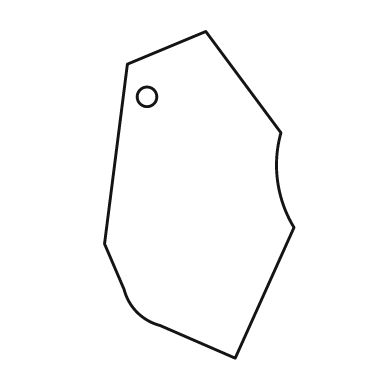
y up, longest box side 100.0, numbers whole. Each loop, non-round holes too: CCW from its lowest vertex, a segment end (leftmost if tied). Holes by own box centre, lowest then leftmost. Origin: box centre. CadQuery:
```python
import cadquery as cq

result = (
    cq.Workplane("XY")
    .moveTo(11.0, -50.0)
    .lineTo(29.0, -10.0)
    .threePointArc((24.0, 4.0), (25.0, 19.0))
    .lineTo(2.0, 50.0)
    .lineTo(-22.0, 40.0)
    .lineTo(-29.0, -15.0)
    .lineTo(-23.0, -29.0)
    .threePointArc((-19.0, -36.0), (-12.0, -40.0))
    .close()
    .moveTo(-16.0, 30.0)
    .circle(3.0)
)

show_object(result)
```